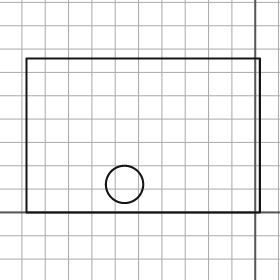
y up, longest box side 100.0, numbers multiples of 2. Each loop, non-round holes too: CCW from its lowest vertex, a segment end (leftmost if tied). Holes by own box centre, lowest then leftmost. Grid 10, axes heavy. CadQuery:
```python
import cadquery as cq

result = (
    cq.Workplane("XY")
    .moveTo(-98.0, 0.0)
    .lineTo(2.0, 0.0)
    .lineTo(2.0, 66.0)
    .lineTo(-98.0, 66.0)
    .close()
    .moveTo(-56.0, 12.0)
    .circle(8.0)
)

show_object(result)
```